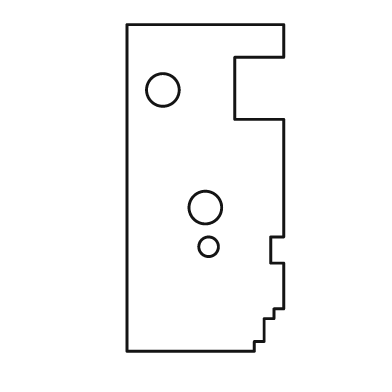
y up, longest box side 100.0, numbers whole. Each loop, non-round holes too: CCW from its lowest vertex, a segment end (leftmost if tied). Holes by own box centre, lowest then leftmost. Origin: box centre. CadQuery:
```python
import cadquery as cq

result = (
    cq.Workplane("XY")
    .moveTo(-24.0, -50.0)
    .lineTo(15.0, -50.0)
    .lineTo(15.0, -47.0)
    .lineTo(18.0, -47.0)
    .lineTo(18.0, -40.0)
    .lineTo(21.0, -40.0)
    .lineTo(21.0, -37.0)
    .lineTo(24.0, -37.0)
    .lineTo(24.0, -23.0)
    .lineTo(20.0, -23.0)
    .lineTo(20.0, -15.0)
    .lineTo(24.0, -15.0)
    .lineTo(24.0, 21.0)
    .lineTo(9.0, 21.0)
    .lineTo(9.0, 40.0)
    .lineTo(24.0, 40.0)
    .lineTo(24.0, 50.0)
    .lineTo(-24.0, 50.0)
    .close()
    .moveTo(1.0, -18.0)
    .circle(3.0)
    .moveTo(0.0, -6.0)
    .circle(5.0)
    .moveTo(-13.0, 30.0)
    .circle(5.0)
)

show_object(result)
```